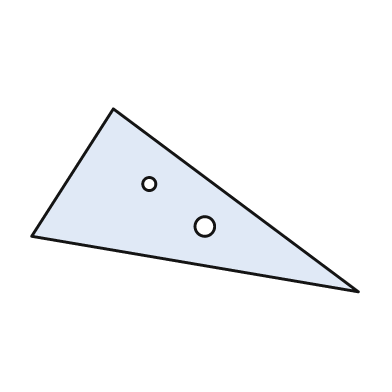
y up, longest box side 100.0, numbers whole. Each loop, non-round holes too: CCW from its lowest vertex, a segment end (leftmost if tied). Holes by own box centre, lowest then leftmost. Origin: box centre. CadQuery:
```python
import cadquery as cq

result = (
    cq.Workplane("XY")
    .moveTo(50.0, -28.0)
    .lineTo(-25.0, 28.0)
    .lineTo(-50.0, -11.0)
    .close()
    .moveTo(3.0, -8.0)
    .circle(3.0)
    .moveTo(-14.0, 5.0)
    .circle(2.0)
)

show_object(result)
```